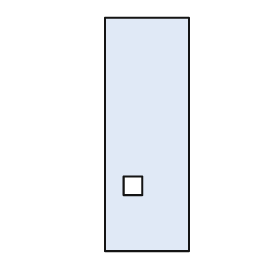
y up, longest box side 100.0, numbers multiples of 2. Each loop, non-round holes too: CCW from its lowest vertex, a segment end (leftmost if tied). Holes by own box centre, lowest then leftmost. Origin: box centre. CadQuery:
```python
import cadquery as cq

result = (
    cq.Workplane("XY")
    .moveTo(-18.0, -50.0)
    .lineTo(18.0, -50.0)
    .lineTo(18.0, 50.0)
    .lineTo(-18.0, 50.0)
    .close()
    .moveTo(-10.0, -26.0)
    .lineTo(-2.0, -26.0)
    .lineTo(-2.0, -18.0)
    .lineTo(-10.0, -18.0)
    .close()
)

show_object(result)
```